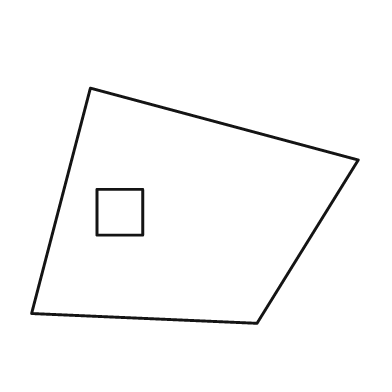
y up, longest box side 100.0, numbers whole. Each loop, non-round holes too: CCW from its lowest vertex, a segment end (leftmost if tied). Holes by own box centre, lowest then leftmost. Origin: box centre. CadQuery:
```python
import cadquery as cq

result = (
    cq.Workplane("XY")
    .moveTo(19.0, -36.0)
    .lineTo(50.0, 14.0)
    .lineTo(-32.0, 36.0)
    .lineTo(-50.0, -33.0)
    .close()
    .moveTo(-30.0, -9.0)
    .lineTo(-16.0, -9.0)
    .lineTo(-16.0, 5.0)
    .lineTo(-30.0, 5.0)
    .close()
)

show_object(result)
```